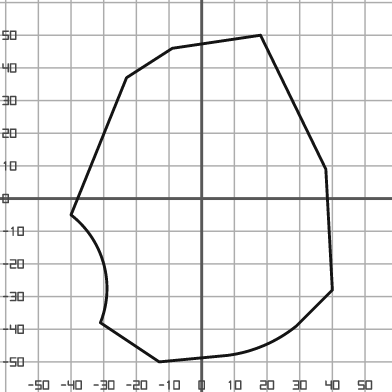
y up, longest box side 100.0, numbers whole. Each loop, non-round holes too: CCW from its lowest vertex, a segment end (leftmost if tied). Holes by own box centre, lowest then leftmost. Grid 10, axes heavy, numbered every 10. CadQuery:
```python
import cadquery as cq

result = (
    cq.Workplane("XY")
    .moveTo(-13.0, -50.0)
    .lineTo(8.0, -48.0)
    .threePointArc((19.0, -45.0), (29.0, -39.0))
    .lineTo(40.0, -28.0)
    .lineTo(38.0, 9.0)
    .lineTo(18.0, 50.0)
    .lineTo(-9.0, 46.0)
    .lineTo(-23.0, 37.0)
    .lineTo(-40.0, -5.0)
    .threePointArc((-30.0, -20.0), (-31.0, -38.0))
    .close()
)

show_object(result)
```